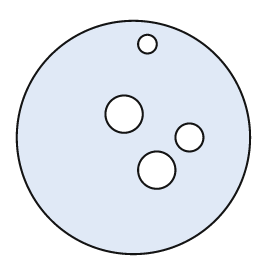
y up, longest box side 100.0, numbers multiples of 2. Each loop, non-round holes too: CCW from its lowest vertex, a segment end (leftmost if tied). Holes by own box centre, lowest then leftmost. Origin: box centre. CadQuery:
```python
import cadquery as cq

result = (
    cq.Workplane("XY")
    .moveTo(0.0, 0.0)
    .circle(50.0)
    .moveTo(10.0, -14.0)
    .circle(8.0)
    .moveTo(24.0, 0.0)
    .circle(6.0)
    .moveTo(-4.0, 10.0)
    .circle(8.0)
    .moveTo(6.0, 40.0)
    .circle(4.0)
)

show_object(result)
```